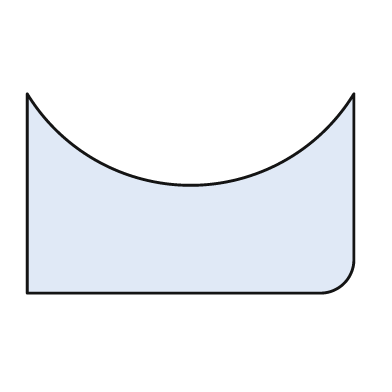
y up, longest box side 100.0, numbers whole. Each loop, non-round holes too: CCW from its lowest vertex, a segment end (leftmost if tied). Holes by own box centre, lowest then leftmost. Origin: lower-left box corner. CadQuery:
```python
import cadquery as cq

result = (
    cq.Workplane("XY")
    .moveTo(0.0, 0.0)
    .lineTo(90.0, 0.0)
    .threePointArc((97.0, 3.0), (100.0, 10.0))
    .lineTo(100.0, 61.0)
    .threePointArc((50.0, 33.0), (0.0, 61.0))
    .close()
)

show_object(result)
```